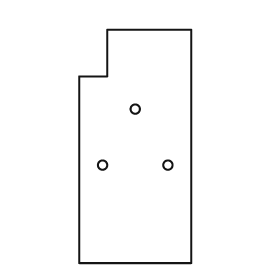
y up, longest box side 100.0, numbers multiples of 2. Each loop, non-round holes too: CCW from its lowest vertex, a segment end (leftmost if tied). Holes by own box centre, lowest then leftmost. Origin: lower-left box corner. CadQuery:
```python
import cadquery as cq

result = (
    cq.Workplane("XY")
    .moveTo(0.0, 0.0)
    .lineTo(48.0, 0.0)
    .lineTo(48.0, 100.0)
    .lineTo(12.0, 100.0)
    .lineTo(12.0, 80.0)
    .lineTo(0.0, 80.0)
    .close()
    .moveTo(10.0, 42.0)
    .circle(2.0)
    .moveTo(38.0, 42.0)
    .circle(2.0)
    .moveTo(24.0, 66.0)
    .circle(2.0)
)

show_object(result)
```